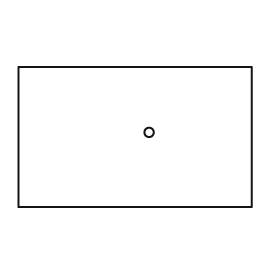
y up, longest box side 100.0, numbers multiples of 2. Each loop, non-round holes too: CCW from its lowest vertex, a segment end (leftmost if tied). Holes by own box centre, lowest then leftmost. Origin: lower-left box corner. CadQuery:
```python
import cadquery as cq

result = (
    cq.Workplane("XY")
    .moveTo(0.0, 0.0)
    .lineTo(100.0, 0.0)
    .lineTo(100.0, 60.0)
    .lineTo(0.0, 60.0)
    .close()
    .moveTo(56.0, 32.0)
    .circle(2.0)
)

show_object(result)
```